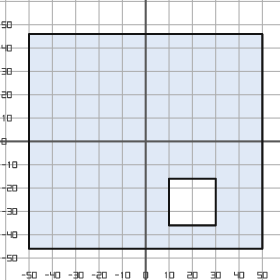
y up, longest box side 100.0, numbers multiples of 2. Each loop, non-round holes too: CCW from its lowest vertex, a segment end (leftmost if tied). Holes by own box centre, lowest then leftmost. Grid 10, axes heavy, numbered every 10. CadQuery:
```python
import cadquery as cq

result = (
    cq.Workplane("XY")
    .moveTo(-50.0, -46.0)
    .lineTo(50.0, -46.0)
    .lineTo(50.0, 46.0)
    .lineTo(-50.0, 46.0)
    .close()
    .moveTo(10.0, -36.0)
    .lineTo(30.0, -36.0)
    .lineTo(30.0, -16.0)
    .lineTo(10.0, -16.0)
    .close()
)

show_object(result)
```